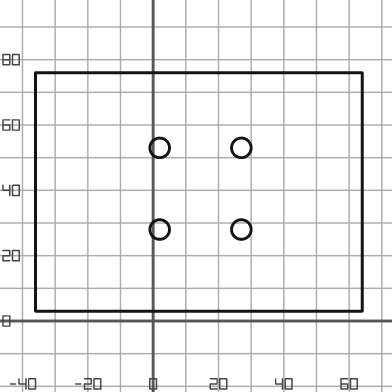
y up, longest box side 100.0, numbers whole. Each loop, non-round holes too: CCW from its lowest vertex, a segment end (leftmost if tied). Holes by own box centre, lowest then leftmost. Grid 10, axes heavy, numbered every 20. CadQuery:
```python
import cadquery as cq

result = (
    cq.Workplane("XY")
    .moveTo(-36.0, 3.0)
    .lineTo(64.0, 3.0)
    .lineTo(64.0, 76.0)
    .lineTo(-36.0, 76.0)
    .close()
    .moveTo(2.0, 28.0)
    .circle(3.0)
    .moveTo(27.0, 28.0)
    .circle(3.0)
    .moveTo(2.0, 53.0)
    .circle(3.0)
    .moveTo(27.0, 53.0)
    .circle(3.0)
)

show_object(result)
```